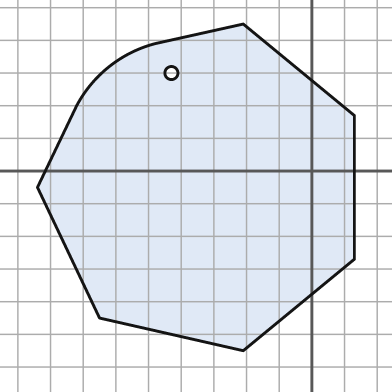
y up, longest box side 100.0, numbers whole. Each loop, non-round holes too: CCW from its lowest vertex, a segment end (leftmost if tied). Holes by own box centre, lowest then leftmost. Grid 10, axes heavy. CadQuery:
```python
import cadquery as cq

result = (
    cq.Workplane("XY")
    .moveTo(-21.0, -55.0)
    .lineTo(13.0, -27.0)
    .lineTo(13.0, 17.0)
    .lineTo(-21.0, 45.0)
    .lineTo(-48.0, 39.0)
    .threePointArc((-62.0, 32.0), (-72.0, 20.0))
    .lineTo(-84.0, -5.0)
    .lineTo(-65.0, -45.0)
    .close()
    .moveTo(-43.0, 30.0)
    .circle(2.0)
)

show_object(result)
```